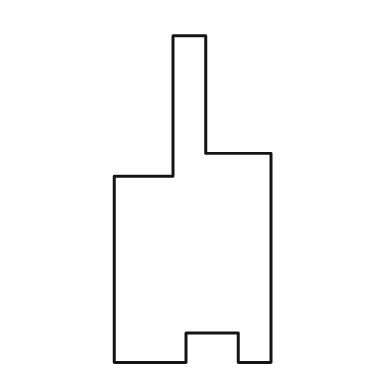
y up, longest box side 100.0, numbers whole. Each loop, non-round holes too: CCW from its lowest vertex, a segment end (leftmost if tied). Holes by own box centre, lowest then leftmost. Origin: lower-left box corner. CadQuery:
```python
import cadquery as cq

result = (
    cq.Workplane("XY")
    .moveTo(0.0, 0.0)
    .lineTo(22.0, 0.0)
    .lineTo(22.0, 9.0)
    .lineTo(38.0, 9.0)
    .lineTo(38.0, 0.0)
    .lineTo(48.0, 0.0)
    .lineTo(48.0, 64.0)
    .lineTo(28.0, 64.0)
    .lineTo(28.0, 100.0)
    .lineTo(18.0, 100.0)
    .lineTo(18.0, 57.0)
    .lineTo(0.0, 57.0)
    .close()
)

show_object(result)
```